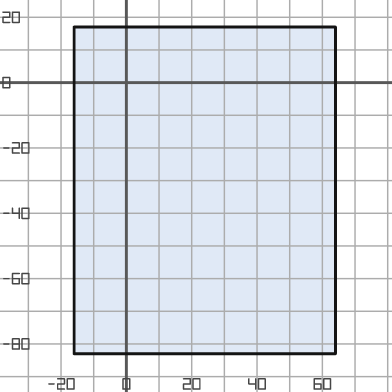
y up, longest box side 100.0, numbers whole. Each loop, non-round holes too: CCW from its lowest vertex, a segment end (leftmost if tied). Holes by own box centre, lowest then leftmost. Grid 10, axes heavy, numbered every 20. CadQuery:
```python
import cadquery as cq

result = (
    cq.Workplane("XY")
    .moveTo(-16.0, -83.0)
    .lineTo(64.0, -83.0)
    .lineTo(64.0, 17.0)
    .lineTo(-16.0, 17.0)
    .close()
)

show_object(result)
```